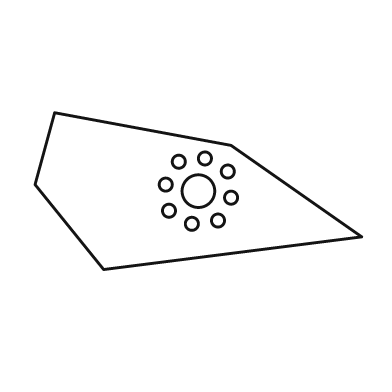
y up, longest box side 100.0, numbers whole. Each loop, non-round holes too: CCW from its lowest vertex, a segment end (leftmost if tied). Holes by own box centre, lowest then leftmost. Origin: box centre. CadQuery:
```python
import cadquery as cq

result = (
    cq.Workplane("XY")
    .moveTo(-29.0, -24.0)
    .lineTo(50.0, -14.0)
    .lineTo(10.0, 14.0)
    .lineTo(-44.0, 24.0)
    .lineTo(-50.0, 2.0)
    .close()
    .moveTo(-2.0, -10.0)
    .circle(2.0)
    .moveTo(6.0, -9.0)
    .circle(2.0)
    .moveTo(-9.0, -6.0)
    .circle(2.0)
    .moveTo(10.0, -2.0)
    .circle(2.0)
    .moveTo(0.0, 0.0)
    .circle(5.0)
    .moveTo(-10.0, 2.0)
    .circle(2.0)
    .moveTo(9.0, 6.0)
    .circle(2.0)
    .moveTo(-6.0, 9.0)
    .circle(2.0)
    .moveTo(2.0, 10.0)
    .circle(2.0)
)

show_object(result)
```